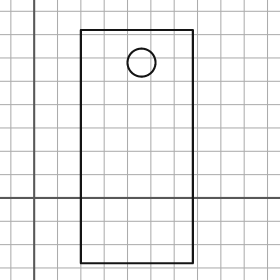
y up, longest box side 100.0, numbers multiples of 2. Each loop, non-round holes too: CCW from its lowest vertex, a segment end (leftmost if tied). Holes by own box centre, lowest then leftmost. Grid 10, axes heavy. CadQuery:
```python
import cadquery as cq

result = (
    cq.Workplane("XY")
    .moveTo(20.0, -28.0)
    .lineTo(68.0, -28.0)
    .lineTo(68.0, 72.0)
    .lineTo(20.0, 72.0)
    .close()
    .moveTo(46.0, 58.0)
    .circle(6.0)
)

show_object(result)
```